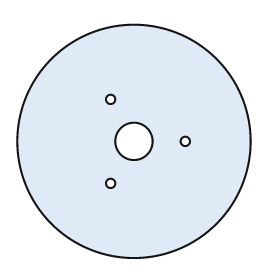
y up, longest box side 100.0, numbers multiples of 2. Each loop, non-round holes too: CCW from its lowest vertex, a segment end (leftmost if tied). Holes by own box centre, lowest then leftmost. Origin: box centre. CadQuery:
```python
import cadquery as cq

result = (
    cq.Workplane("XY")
    .moveTo(0.0, 0.0)
    .circle(50.0)
    .moveTo(-10.0, -18.0)
    .circle(2.0)
    .moveTo(0.0, 0.0)
    .circle(8.0)
    .moveTo(22.0, 0.0)
    .circle(2.0)
    .moveTo(-10.0, 18.0)
    .circle(2.0)
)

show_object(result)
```